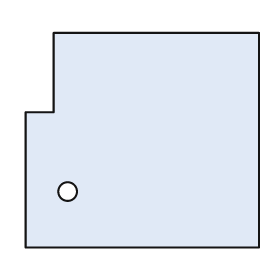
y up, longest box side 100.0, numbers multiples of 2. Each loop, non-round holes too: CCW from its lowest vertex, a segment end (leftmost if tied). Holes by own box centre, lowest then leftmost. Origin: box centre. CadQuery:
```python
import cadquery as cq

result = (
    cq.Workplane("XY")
    .moveTo(-50.0, -46.0)
    .lineTo(50.0, -46.0)
    .lineTo(50.0, 46.0)
    .lineTo(-38.0, 46.0)
    .lineTo(-38.0, 12.0)
    .lineTo(-50.0, 12.0)
    .close()
    .moveTo(-32.0, -22.0)
    .circle(4.0)
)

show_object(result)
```